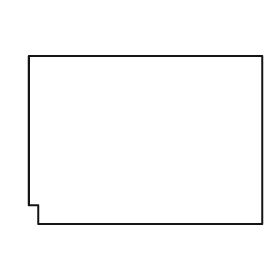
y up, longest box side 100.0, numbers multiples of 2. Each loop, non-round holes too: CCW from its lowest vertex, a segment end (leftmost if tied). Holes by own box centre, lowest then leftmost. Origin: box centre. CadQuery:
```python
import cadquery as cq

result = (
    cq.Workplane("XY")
    .moveTo(-46.0, -36.0)
    .lineTo(50.0, -36.0)
    .lineTo(50.0, 36.0)
    .lineTo(-50.0, 36.0)
    .lineTo(-50.0, -28.0)
    .lineTo(-46.0, -28.0)
    .close()
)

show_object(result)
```